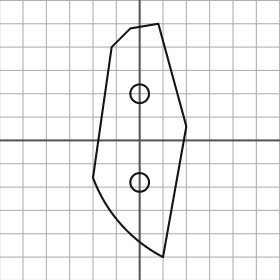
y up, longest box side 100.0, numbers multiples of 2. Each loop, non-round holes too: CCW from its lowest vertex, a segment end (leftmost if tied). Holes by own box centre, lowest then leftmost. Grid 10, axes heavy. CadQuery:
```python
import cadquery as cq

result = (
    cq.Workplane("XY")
    .moveTo(10.0, -50.0)
    .lineTo(20.0, 6.0)
    .lineTo(8.0, 50.0)
    .lineTo(-4.0, 48.0)
    .lineTo(-12.0, 40.0)
    .lineTo(-20.0, -16.0)
    .threePointArc((-8.0, -36.0), (10.0, -50.0))
    .close()
    .moveTo(0.0, -18.0)
    .circle(4.0)
    .moveTo(0.0, 20.0)
    .circle(4.0)
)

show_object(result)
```